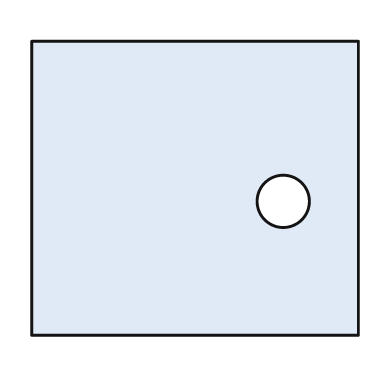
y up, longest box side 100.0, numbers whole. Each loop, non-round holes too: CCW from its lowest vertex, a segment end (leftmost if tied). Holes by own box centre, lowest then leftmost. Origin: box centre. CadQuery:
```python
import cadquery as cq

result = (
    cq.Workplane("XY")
    .moveTo(-50.0, -45.0)
    .lineTo(50.0, -45.0)
    .lineTo(50.0, 45.0)
    .lineTo(-50.0, 45.0)
    .close()
    .moveTo(27.0, -4.0)
    .circle(8.0)
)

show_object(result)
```